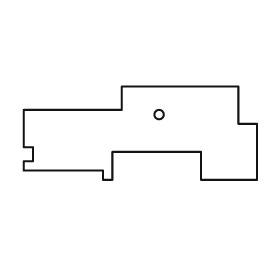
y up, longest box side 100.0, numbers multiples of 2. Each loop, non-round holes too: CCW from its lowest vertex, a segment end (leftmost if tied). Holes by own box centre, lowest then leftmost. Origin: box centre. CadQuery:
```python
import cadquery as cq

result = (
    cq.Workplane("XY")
    .moveTo(-16.0, -20.0)
    .lineTo(-12.0, -20.0)
    .lineTo(-12.0, -8.0)
    .lineTo(26.0, -8.0)
    .lineTo(26.0, -20.0)
    .lineTo(50.0, -20.0)
    .lineTo(50.0, 4.0)
    .lineTo(42.0, 4.0)
    .lineTo(42.0, 20.0)
    .lineTo(-8.0, 20.0)
    .lineTo(-8.0, 10.0)
    .lineTo(-50.0, 10.0)
    .lineTo(-50.0, -6.0)
    .lineTo(-46.0, -6.0)
    .lineTo(-46.0, -12.0)
    .lineTo(-50.0, -12.0)
    .lineTo(-50.0, -16.0)
    .lineTo(-16.0, -16.0)
    .close()
    .moveTo(8.0, 8.0)
    .circle(2.0)
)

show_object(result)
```